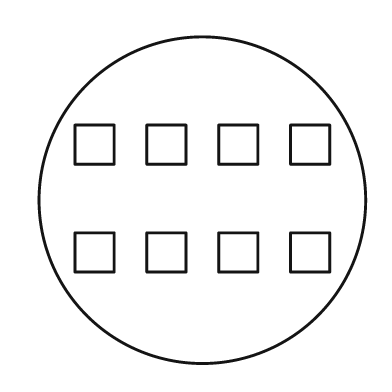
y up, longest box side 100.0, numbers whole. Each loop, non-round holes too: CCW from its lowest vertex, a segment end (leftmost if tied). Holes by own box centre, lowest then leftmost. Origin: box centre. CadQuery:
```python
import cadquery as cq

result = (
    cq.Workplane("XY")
    .moveTo(0.0, 0.0)
    .circle(50.0)
    .moveTo(-39.0, -22.0)
    .lineTo(-27.0, -22.0)
    .lineTo(-27.0, -10.0)
    .lineTo(-39.0, -10.0)
    .close()
    .moveTo(-17.0, -22.0)
    .lineTo(-5.0, -22.0)
    .lineTo(-5.0, -10.0)
    .lineTo(-17.0, -10.0)
    .close()
    .moveTo(5.0, -22.0)
    .lineTo(17.0, -22.0)
    .lineTo(17.0, -10.0)
    .lineTo(5.0, -10.0)
    .close()
    .moveTo(27.0, -22.0)
    .lineTo(39.0, -22.0)
    .lineTo(39.0, -10.0)
    .lineTo(27.0, -10.0)
    .close()
    .moveTo(-39.0, 11.0)
    .lineTo(-27.0, 11.0)
    .lineTo(-27.0, 23.0)
    .lineTo(-39.0, 23.0)
    .close()
    .moveTo(-17.0, 11.0)
    .lineTo(-5.0, 11.0)
    .lineTo(-5.0, 23.0)
    .lineTo(-17.0, 23.0)
    .close()
    .moveTo(5.0, 11.0)
    .lineTo(17.0, 11.0)
    .lineTo(17.0, 23.0)
    .lineTo(5.0, 23.0)
    .close()
    .moveTo(27.0, 11.0)
    .lineTo(39.0, 11.0)
    .lineTo(39.0, 23.0)
    .lineTo(27.0, 23.0)
    .close()
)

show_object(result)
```